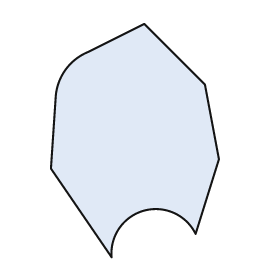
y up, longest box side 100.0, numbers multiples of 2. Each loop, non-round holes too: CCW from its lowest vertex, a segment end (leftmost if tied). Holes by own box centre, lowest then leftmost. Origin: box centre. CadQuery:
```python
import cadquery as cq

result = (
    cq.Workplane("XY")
    .moveTo(-10.0, -50.0)
    .threePointArc((4.0, -30.0), (26.0, -40.0))
    .lineTo(36.0, -8.0)
    .lineTo(30.0, 24.0)
    .lineTo(4.0, 50.0)
    .lineTo(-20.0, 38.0)
    .threePointArc((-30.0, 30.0), (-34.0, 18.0))
    .lineTo(-36.0, -12.0)
    .close()
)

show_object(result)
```